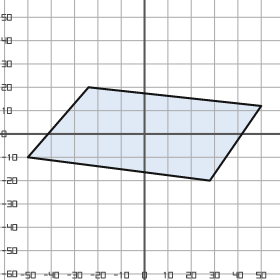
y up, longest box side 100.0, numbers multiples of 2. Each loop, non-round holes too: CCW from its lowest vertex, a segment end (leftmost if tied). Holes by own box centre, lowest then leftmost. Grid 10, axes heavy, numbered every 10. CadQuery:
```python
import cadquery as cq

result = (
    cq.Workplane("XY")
    .moveTo(28.0, -20.0)
    .lineTo(50.0, 12.0)
    .lineTo(-24.0, 20.0)
    .lineTo(-50.0, -10.0)
    .close()
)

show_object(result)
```